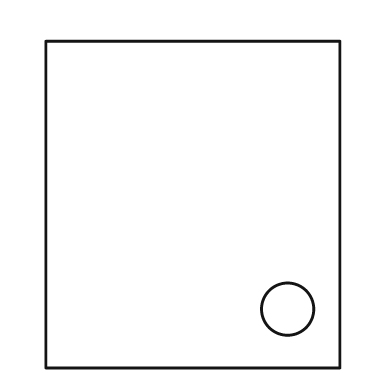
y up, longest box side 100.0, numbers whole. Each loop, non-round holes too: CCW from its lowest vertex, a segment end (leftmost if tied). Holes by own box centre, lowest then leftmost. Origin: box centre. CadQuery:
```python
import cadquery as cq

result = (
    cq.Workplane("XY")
    .moveTo(-45.0, -50.0)
    .lineTo(45.0, -50.0)
    .lineTo(45.0, 50.0)
    .lineTo(-45.0, 50.0)
    .close()
    .moveTo(29.0, -32.0)
    .circle(8.0)
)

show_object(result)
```